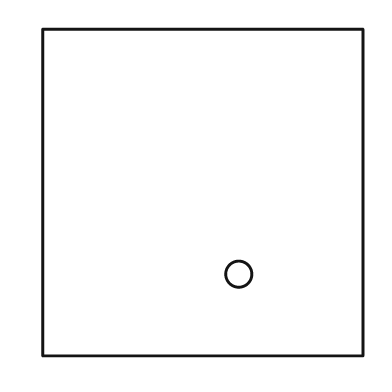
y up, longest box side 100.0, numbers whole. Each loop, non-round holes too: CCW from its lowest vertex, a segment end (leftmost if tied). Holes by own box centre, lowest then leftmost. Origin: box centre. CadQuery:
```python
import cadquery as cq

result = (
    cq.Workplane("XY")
    .moveTo(-49.0, -50.0)
    .lineTo(49.0, -50.0)
    .lineTo(49.0, 50.0)
    .lineTo(-49.0, 50.0)
    .close()
    .moveTo(11.0, -25.0)
    .circle(4.0)
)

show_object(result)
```